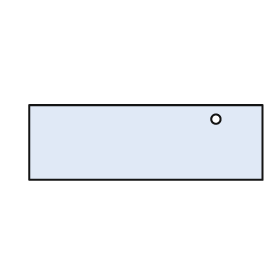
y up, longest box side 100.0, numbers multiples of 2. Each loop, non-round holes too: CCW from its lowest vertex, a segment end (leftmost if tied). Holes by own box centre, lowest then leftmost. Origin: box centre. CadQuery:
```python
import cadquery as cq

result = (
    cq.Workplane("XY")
    .moveTo(-50.0, -16.0)
    .lineTo(50.0, -16.0)
    .lineTo(50.0, 16.0)
    .lineTo(-50.0, 16.0)
    .close()
    .moveTo(30.0, 10.0)
    .circle(2.0)
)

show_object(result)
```